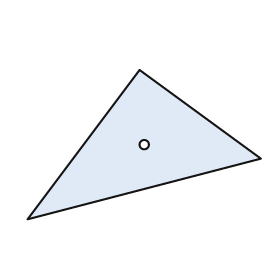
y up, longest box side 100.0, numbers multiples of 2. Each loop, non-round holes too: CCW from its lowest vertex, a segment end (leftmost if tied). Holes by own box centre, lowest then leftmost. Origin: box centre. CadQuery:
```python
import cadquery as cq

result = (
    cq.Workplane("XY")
    .moveTo(-50.0, -32.0)
    .lineTo(50.0, -6.0)
    .lineTo(-2.0, 32.0)
    .close()
    .moveTo(0.0, 0.0)
    .circle(2.0)
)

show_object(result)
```